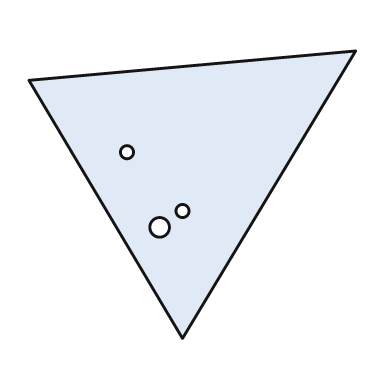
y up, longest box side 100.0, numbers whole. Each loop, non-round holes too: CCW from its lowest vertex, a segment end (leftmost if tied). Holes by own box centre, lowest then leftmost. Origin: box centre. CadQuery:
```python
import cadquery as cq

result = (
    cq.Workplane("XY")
    .moveTo(-3.0, -44.0)
    .lineTo(50.0, 44.0)
    .lineTo(-50.0, 35.0)
    .close()
    .moveTo(-10.0, -10.0)
    .circle(3.0)
    .moveTo(-3.0, -5.0)
    .circle(2.0)
    .moveTo(-20.0, 13.0)
    .circle(2.0)
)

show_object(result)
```